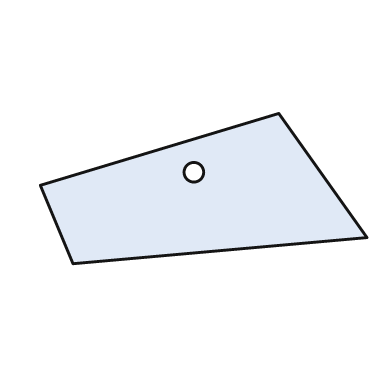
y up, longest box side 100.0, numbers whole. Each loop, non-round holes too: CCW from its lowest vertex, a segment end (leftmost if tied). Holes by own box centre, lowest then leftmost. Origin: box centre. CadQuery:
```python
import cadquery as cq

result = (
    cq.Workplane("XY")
    .moveTo(-40.0, -23.0)
    .lineTo(50.0, -15.0)
    .lineTo(23.0, 23.0)
    .lineTo(-50.0, 1.0)
    .close()
    .moveTo(-3.0, 5.0)
    .circle(3.0)
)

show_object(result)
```